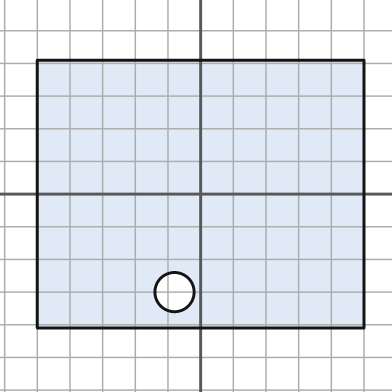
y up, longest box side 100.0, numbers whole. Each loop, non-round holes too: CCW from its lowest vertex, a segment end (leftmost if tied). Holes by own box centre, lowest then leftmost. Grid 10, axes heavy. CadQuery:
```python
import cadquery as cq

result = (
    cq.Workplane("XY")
    .moveTo(-50.0, -41.0)
    .lineTo(50.0, -41.0)
    .lineTo(50.0, 41.0)
    .lineTo(-50.0, 41.0)
    .close()
    .moveTo(-8.0, -30.0)
    .circle(6.0)
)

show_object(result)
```